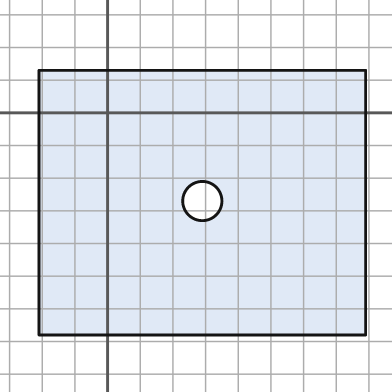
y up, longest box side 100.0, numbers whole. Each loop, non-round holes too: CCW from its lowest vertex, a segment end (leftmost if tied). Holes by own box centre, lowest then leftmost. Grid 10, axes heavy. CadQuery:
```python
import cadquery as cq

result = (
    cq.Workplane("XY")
    .moveTo(-21.0, -68.0)
    .lineTo(79.0, -68.0)
    .lineTo(79.0, 13.0)
    .lineTo(-21.0, 13.0)
    .close()
    .moveTo(29.0, -27.0)
    .circle(6.0)
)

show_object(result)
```